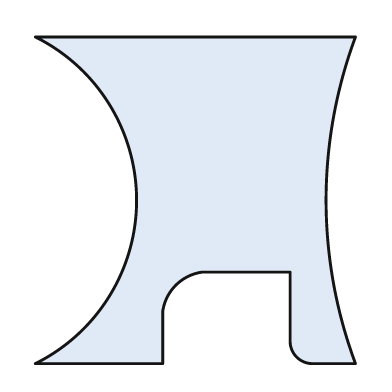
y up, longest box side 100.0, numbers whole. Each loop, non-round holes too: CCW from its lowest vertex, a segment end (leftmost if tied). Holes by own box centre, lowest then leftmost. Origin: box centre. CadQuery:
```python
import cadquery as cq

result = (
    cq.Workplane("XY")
    .moveTo(-49.0, -50.0)
    .lineTo(-10.0, -50.0)
    .lineTo(-10.0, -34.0)
    .threePointArc((-6.0, -26.0), (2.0, -22.0))
    .lineTo(29.0, -22.0)
    .lineTo(29.0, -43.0)
    .threePointArc((31.0, -48.0), (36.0, -50.0))
    .lineTo(49.0, -50.0)
    .threePointArc((40.0, 0.0), (49.0, 50.0))
    .lineTo(-49.0, 50.0)
    .threePointArc((-18.0, 0.0), (-49.0, -50.0))
    .close()
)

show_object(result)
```